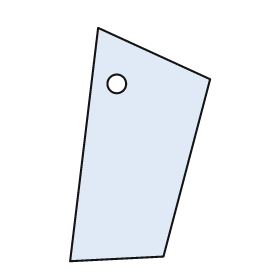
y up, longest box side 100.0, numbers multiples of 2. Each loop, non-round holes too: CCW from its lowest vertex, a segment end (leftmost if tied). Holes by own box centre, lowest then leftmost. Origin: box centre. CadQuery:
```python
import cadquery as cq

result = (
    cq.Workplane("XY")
    .moveTo(-30.0, -50.0)
    .lineTo(10.0, -48.0)
    .lineTo(30.0, 28.0)
    .lineTo(-18.0, 50.0)
    .close()
    .moveTo(-10.0, 26.0)
    .circle(4.0)
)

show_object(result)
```